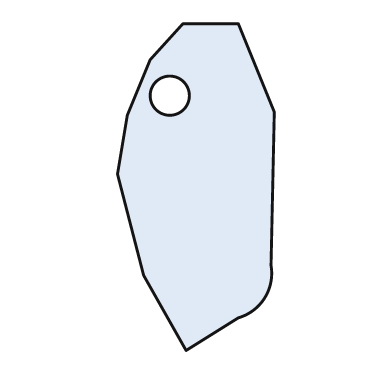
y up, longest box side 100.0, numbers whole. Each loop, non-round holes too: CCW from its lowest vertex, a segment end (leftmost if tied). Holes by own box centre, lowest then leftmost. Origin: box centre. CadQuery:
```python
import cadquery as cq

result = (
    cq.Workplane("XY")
    .moveTo(-3.0, -50.0)
    .lineTo(13.0, -40.0)
    .threePointArc((21.0, -34.0), (23.0, -24.0))
    .lineTo(24.0, 23.0)
    .lineTo(13.0, 50.0)
    .lineTo(-4.0, 50.0)
    .lineTo(-14.0, 39.0)
    .lineTo(-21.0, 22.0)
    .lineTo(-24.0, 4.0)
    .lineTo(-16.0, -27.0)
    .close()
    .moveTo(-8.0, 28.0)
    .circle(6.0)
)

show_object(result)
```